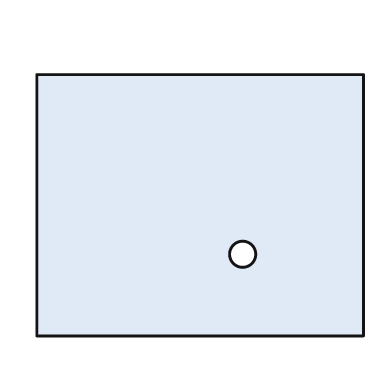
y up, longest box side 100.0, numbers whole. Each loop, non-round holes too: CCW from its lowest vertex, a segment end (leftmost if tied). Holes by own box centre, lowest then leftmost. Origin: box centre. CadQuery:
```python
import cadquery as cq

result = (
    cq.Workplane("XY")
    .moveTo(-50.0, -40.0)
    .lineTo(50.0, -40.0)
    .lineTo(50.0, 40.0)
    .lineTo(-50.0, 40.0)
    .close()
    .moveTo(13.0, -15.0)
    .circle(4.0)
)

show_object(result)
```